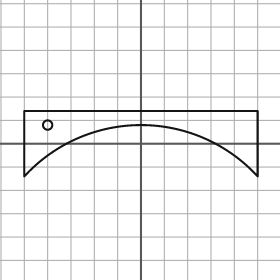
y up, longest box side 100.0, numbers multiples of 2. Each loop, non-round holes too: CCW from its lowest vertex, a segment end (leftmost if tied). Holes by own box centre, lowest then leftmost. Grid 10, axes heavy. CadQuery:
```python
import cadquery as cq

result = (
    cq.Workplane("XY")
    .moveTo(-50.0, -14.0)
    .threePointArc((0.0, 8.0), (50.0, -14.0))
    .lineTo(50.0, 14.0)
    .lineTo(-50.0, 14.0)
    .close()
    .moveTo(-40.0, 8.0)
    .circle(2.0)
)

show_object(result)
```